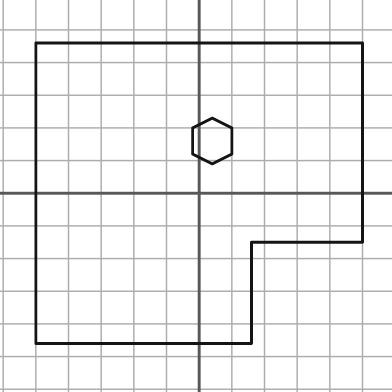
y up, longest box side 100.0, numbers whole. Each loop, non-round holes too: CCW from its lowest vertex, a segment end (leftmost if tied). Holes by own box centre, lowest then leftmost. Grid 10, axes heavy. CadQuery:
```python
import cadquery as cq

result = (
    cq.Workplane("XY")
    .moveTo(-50.0, -46.0)
    .lineTo(16.0, -46.0)
    .lineTo(16.0, -15.0)
    .lineTo(50.0, -15.0)
    .lineTo(50.0, 46.0)
    .lineTo(-50.0, 46.0)
    .close()
    .moveTo(4.0, 9.0)
    .lineTo(10.0, 12.0)
    .lineTo(10.0, 20.0)
    .lineTo(4.0, 23.0)
    .lineTo(-2.0, 20.0)
    .lineTo(-2.0, 12.0)
    .close()
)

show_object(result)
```